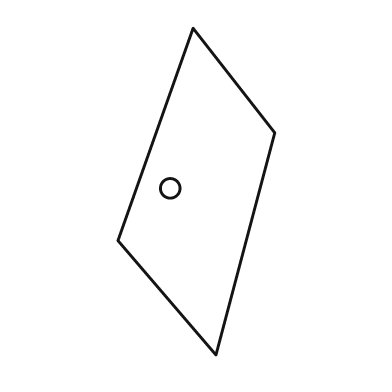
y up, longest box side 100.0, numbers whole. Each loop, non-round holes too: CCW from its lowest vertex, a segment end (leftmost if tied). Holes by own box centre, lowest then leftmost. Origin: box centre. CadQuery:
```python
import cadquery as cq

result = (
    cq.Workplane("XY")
    .moveTo(6.0, -50.0)
    .lineTo(24.0, 18.0)
    .lineTo(-1.0, 50.0)
    .lineTo(-24.0, -15.0)
    .close()
    .moveTo(-8.0, 1.0)
    .circle(3.0)
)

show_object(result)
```